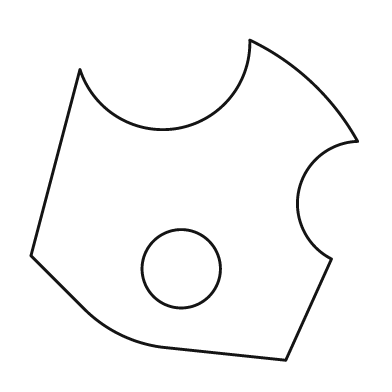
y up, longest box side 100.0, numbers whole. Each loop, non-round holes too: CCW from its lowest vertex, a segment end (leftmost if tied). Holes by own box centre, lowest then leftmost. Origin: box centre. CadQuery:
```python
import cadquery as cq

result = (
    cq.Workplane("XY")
    .moveTo(28.0, -49.0)
    .lineTo(42.0, -18.0)
    .threePointArc((32.0, 3.0), (50.0, 18.0))
    .threePointArc((36.0, 36.0), (17.0, 49.0))
    .threePointArc((-5.0, 22.0), (-35.0, 40.0))
    .lineTo(-50.0, -17.0)
    .lineTo(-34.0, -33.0)
    .threePointArc((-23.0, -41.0), (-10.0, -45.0))
    .close()
    .moveTo(-4.0, -21.0)
    .circle(12.0)
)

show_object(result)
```